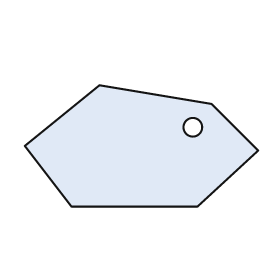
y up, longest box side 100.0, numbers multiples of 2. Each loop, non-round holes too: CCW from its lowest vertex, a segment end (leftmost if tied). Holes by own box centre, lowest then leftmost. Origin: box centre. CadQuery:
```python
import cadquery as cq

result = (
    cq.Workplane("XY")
    .moveTo(-30.0, -26.0)
    .lineTo(24.0, -26.0)
    .lineTo(50.0, -2.0)
    .lineTo(30.0, 18.0)
    .lineTo(-18.0, 26.0)
    .lineTo(-50.0, 0.0)
    .close()
    .moveTo(22.0, 8.0)
    .circle(4.0)
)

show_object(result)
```